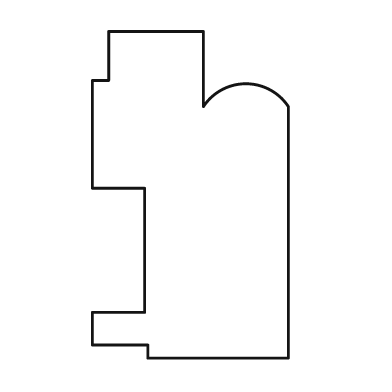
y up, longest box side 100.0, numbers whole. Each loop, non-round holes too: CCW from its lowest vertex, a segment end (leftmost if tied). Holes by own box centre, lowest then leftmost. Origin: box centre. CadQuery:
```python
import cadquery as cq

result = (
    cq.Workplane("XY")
    .moveTo(-13.0, -50.0)
    .lineTo(30.0, -50.0)
    .lineTo(30.0, 27.0)
    .threePointArc((17.0, 34.0), (4.0, 27.0))
    .lineTo(4.0, 50.0)
    .lineTo(-25.0, 50.0)
    .lineTo(-25.0, 35.0)
    .lineTo(-30.0, 35.0)
    .lineTo(-30.0, 2.0)
    .lineTo(-14.0, 2.0)
    .lineTo(-14.0, -36.0)
    .lineTo(-30.0, -36.0)
    .lineTo(-30.0, -46.0)
    .lineTo(-13.0, -46.0)
    .close()
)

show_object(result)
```